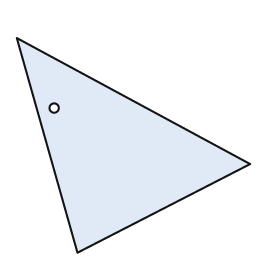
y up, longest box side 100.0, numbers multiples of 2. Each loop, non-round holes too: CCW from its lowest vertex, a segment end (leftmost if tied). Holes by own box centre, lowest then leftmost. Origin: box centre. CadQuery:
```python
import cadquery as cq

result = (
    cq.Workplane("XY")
    .moveTo(-24.0, -46.0)
    .lineTo(50.0, -8.0)
    .lineTo(-50.0, 46.0)
    .close()
    .moveTo(-34.0, 16.0)
    .circle(2.0)
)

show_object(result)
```